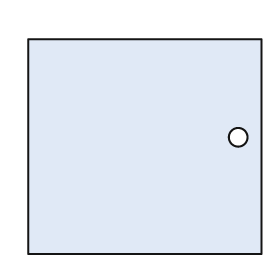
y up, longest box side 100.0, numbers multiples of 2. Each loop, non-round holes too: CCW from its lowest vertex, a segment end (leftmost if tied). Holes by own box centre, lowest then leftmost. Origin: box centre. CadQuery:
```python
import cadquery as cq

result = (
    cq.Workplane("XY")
    .moveTo(-50.0, -46.0)
    .lineTo(50.0, -46.0)
    .lineTo(50.0, 46.0)
    .lineTo(-50.0, 46.0)
    .close()
    .moveTo(40.0, 4.0)
    .circle(4.0)
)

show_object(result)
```